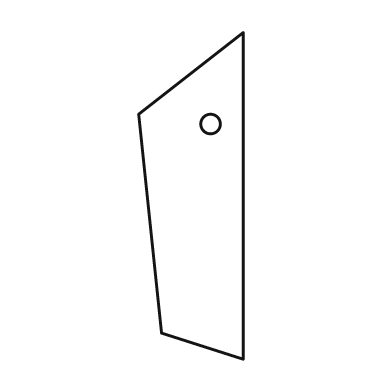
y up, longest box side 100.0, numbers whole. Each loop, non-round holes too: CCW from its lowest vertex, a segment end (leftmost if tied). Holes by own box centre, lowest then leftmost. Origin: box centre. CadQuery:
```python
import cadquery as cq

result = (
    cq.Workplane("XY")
    .moveTo(16.0, -50.0)
    .lineTo(16.0, 50.0)
    .lineTo(-16.0, 25.0)
    .lineTo(-9.0, -42.0)
    .close()
    .moveTo(6.0, 22.0)
    .circle(3.0)
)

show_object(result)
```